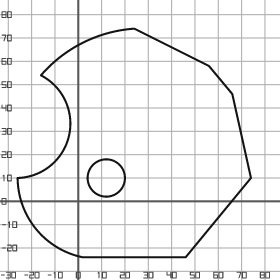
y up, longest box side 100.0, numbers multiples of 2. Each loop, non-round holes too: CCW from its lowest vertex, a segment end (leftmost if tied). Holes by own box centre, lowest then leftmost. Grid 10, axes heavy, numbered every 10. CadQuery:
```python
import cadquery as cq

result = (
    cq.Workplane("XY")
    .moveTo(2.0, -24.0)
    .lineTo(46.0, -24.0)
    .lineTo(74.0, 10.0)
    .lineTo(66.0, 46.0)
    .lineTo(56.0, 58.0)
    .lineTo(24.0, 74.0)
    .threePointArc((2.0, 68.0), (-16.0, 54.0))
    .threePointArc((-4.0, 28.0), (-26.0, 10.0))
    .threePointArc((-18.0, -12.0), (2.0, -24.0))
    .close()
    .moveTo(12.0, 10.0)
    .circle(8.0)
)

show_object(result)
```